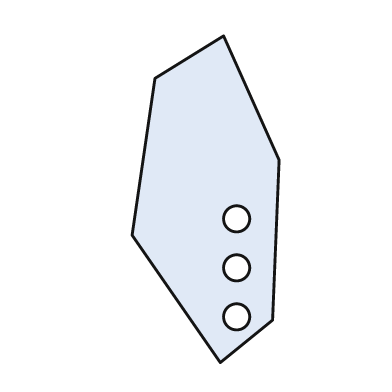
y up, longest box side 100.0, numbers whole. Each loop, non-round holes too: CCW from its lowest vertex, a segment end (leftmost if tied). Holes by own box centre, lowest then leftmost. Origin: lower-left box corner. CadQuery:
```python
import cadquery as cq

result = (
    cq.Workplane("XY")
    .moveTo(27.0, 0.0)
    .lineTo(43.0, 13.0)
    .lineTo(45.0, 62.0)
    .lineTo(28.0, 100.0)
    .lineTo(7.0, 87.0)
    .lineTo(0.0, 39.0)
    .close()
    .moveTo(32.0, 14.0)
    .circle(4.0)
    .moveTo(32.0, 29.0)
    .circle(4.0)
    .moveTo(32.0, 44.0)
    .circle(4.0)
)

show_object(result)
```